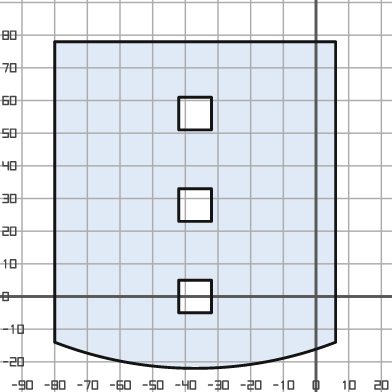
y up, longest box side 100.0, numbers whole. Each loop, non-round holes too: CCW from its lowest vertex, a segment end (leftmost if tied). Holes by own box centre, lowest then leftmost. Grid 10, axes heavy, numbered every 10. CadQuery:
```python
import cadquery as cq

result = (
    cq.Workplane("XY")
    .moveTo(-80.0, -14.0)
    .threePointArc((-37.0, -22.0), (6.0, -14.0))
    .lineTo(6.0, 78.0)
    .lineTo(-80.0, 78.0)
    .close()
    .moveTo(-42.0, -5.0)
    .lineTo(-32.0, -5.0)
    .lineTo(-32.0, 5.0)
    .lineTo(-42.0, 5.0)
    .close()
    .moveTo(-42.0, 23.0)
    .lineTo(-32.0, 23.0)
    .lineTo(-32.0, 33.0)
    .lineTo(-42.0, 33.0)
    .close()
    .moveTo(-42.0, 51.0)
    .lineTo(-32.0, 51.0)
    .lineTo(-32.0, 61.0)
    .lineTo(-42.0, 61.0)
    .close()
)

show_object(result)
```